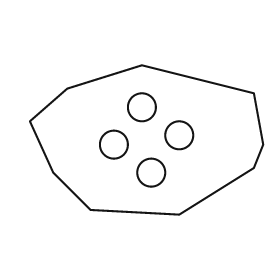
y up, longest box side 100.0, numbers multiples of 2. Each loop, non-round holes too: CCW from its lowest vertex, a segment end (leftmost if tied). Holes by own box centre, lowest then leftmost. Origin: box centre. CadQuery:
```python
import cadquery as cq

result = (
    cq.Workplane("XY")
    .moveTo(14.0, -32.0)
    .lineTo(46.0, -12.0)
    .lineTo(50.0, -2.0)
    .lineTo(46.0, 20.0)
    .lineTo(-2.0, 32.0)
    .lineTo(-34.0, 22.0)
    .lineTo(-50.0, 8.0)
    .lineTo(-40.0, -14.0)
    .lineTo(-24.0, -30.0)
    .close()
    .moveTo(2.0, -14.0)
    .circle(6.0)
    .moveTo(-14.0, -2.0)
    .circle(6.0)
    .moveTo(14.0, 2.0)
    .circle(6.0)
    .moveTo(-2.0, 14.0)
    .circle(6.0)
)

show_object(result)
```